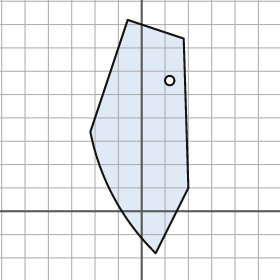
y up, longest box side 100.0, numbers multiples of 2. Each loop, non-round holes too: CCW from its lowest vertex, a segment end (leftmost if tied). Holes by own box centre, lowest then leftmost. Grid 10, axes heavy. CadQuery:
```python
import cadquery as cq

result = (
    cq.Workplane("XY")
    .moveTo(6.0, -18.0)
    .lineTo(20.0, 10.0)
    .lineTo(18.0, 74.0)
    .lineTo(-6.0, 82.0)
    .lineTo(-22.0, 34.0)
    .threePointArc((-12.0, 6.0), (6.0, -18.0))
    .close()
    .moveTo(12.0, 56.0)
    .circle(2.0)
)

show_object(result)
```